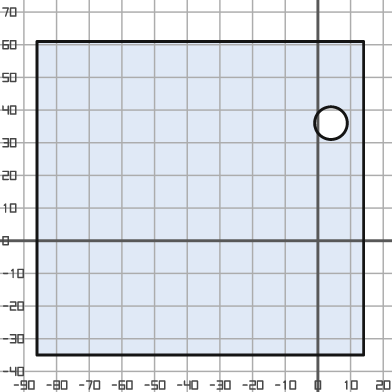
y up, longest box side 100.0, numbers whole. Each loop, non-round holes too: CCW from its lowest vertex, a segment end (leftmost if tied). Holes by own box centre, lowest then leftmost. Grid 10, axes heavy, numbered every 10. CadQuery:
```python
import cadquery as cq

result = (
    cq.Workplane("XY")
    .moveTo(-86.0, -35.0)
    .lineTo(14.0, -35.0)
    .lineTo(14.0, 61.0)
    .lineTo(-86.0, 61.0)
    .close()
    .moveTo(4.0, 36.0)
    .circle(5.0)
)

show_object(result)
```